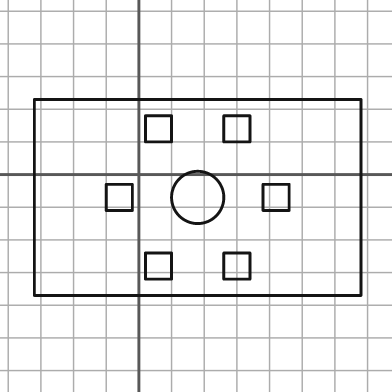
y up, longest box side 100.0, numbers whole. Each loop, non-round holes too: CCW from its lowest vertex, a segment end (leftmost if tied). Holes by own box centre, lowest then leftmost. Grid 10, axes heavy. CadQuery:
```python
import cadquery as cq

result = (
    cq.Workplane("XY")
    .moveTo(-32.0, -37.0)
    .lineTo(68.0, -37.0)
    .lineTo(68.0, 23.0)
    .lineTo(-32.0, 23.0)
    .close()
    .moveTo(2.0, -32.0)
    .lineTo(10.0, -32.0)
    .lineTo(10.0, -24.0)
    .lineTo(2.0, -24.0)
    .close()
    .moveTo(26.0, -32.0)
    .lineTo(34.0, -32.0)
    .lineTo(34.0, -24.0)
    .lineTo(26.0, -24.0)
    .close()
    .moveTo(-10.0, -11.0)
    .lineTo(-2.0, -11.0)
    .lineTo(-2.0, -3.0)
    .lineTo(-10.0, -3.0)
    .close()
    .moveTo(18.0, -7.0)
    .circle(8.0)
    .moveTo(38.0, -11.0)
    .lineTo(46.0, -11.0)
    .lineTo(46.0, -3.0)
    .lineTo(38.0, -3.0)
    .close()
    .moveTo(2.0, 10.0)
    .lineTo(10.0, 10.0)
    .lineTo(10.0, 18.0)
    .lineTo(2.0, 18.0)
    .close()
    .moveTo(26.0, 10.0)
    .lineTo(34.0, 10.0)
    .lineTo(34.0, 18.0)
    .lineTo(26.0, 18.0)
    .close()
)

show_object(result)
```